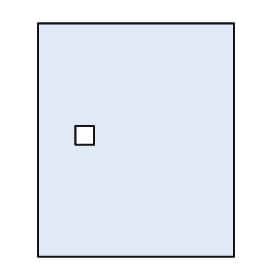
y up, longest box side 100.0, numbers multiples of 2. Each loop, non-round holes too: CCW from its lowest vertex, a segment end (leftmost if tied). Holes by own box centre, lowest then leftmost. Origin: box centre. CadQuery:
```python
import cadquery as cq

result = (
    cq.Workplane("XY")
    .moveTo(-42.0, -50.0)
    .lineTo(42.0, -50.0)
    .lineTo(42.0, 50.0)
    .lineTo(-42.0, 50.0)
    .close()
    .moveTo(-26.0, -2.0)
    .lineTo(-18.0, -2.0)
    .lineTo(-18.0, 6.0)
    .lineTo(-26.0, 6.0)
    .close()
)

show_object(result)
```